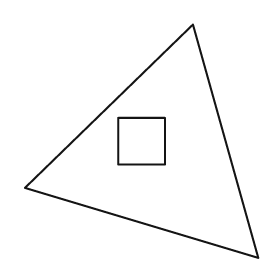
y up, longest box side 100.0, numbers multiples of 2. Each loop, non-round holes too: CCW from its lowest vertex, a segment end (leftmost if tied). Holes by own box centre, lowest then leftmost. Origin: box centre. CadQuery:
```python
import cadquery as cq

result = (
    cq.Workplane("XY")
    .moveTo(50.0, -50.0)
    .lineTo(22.0, 50.0)
    .lineTo(-50.0, -20.0)
    .close()
    .moveTo(-10.0, -10.0)
    .lineTo(10.0, -10.0)
    .lineTo(10.0, 10.0)
    .lineTo(-10.0, 10.0)
    .close()
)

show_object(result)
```